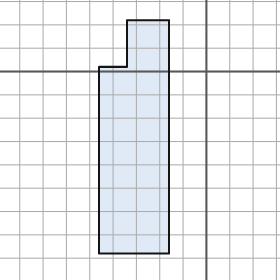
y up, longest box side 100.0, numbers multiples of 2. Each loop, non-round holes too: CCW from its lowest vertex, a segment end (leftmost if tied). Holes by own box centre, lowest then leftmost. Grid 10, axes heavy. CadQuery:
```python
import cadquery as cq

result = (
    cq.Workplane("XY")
    .moveTo(-46.0, -78.0)
    .lineTo(-16.0, -78.0)
    .lineTo(-16.0, 22.0)
    .lineTo(-34.0, 22.0)
    .lineTo(-34.0, 2.0)
    .lineTo(-46.0, 2.0)
    .close()
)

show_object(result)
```